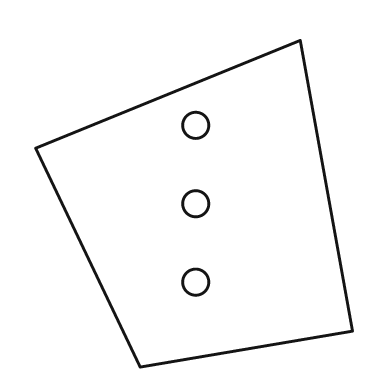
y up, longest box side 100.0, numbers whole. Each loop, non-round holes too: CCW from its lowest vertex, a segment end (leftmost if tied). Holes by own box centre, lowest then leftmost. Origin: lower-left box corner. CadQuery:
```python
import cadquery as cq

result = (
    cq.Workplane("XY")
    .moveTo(32.0, 0.0)
    .lineTo(97.0, 11.0)
    .lineTo(81.0, 100.0)
    .lineTo(0.0, 67.0)
    .close()
    .moveTo(49.0, 26.0)
    .circle(4.0)
    .moveTo(49.0, 50.0)
    .circle(4.0)
    .moveTo(49.0, 74.0)
    .circle(4.0)
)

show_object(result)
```